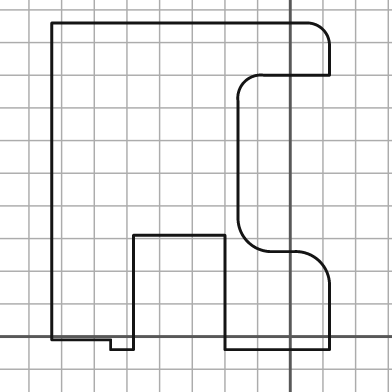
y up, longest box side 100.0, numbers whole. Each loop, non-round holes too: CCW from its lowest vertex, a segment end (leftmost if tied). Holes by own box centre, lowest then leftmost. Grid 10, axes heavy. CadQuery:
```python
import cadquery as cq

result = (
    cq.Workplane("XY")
    .moveTo(-55.0, -4.0)
    .lineTo(-48.0, -4.0)
    .lineTo(-48.0, 31.0)
    .lineTo(-20.0, 31.0)
    .lineTo(-20.0, -4.0)
    .lineTo(12.0, -4.0)
    .lineTo(12.0, 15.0)
    .threePointArc((9.0, 23.0), (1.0, 26.0))
    .lineTo(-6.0, 26.0)
    .threePointArc((-13.0, 29.0), (-16.0, 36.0))
    .lineTo(-16.0, 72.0)
    .threePointArc((-14.0, 78.0), (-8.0, 80.0))
    .lineTo(12.0, 80.0)
    .lineTo(12.0, 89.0)
    .threePointArc((10.0, 94.0), (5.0, 96.0))
    .lineTo(-73.0, 96.0)
    .lineTo(-73.0, -1.0)
    .lineTo(-55.0, -1.0)
    .close()
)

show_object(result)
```